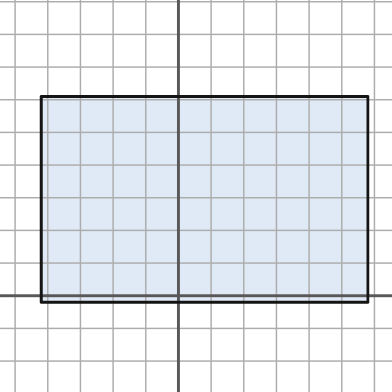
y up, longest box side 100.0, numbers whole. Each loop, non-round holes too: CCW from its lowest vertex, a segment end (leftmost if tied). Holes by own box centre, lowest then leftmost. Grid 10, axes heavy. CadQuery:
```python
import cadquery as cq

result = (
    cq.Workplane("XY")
    .moveTo(-42.0, -2.0)
    .lineTo(58.0, -2.0)
    .lineTo(58.0, 61.0)
    .lineTo(-42.0, 61.0)
    .close()
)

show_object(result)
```